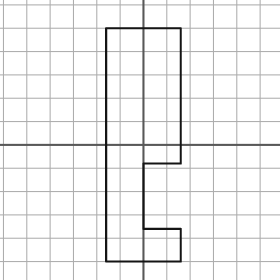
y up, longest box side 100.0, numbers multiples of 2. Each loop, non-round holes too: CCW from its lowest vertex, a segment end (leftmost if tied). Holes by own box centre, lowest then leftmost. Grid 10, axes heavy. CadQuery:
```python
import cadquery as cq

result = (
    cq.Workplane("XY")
    .moveTo(-16.0, -50.0)
    .lineTo(16.0, -50.0)
    .lineTo(16.0, -36.0)
    .lineTo(0.0, -36.0)
    .lineTo(0.0, -8.0)
    .lineTo(16.0, -8.0)
    .lineTo(16.0, 50.0)
    .lineTo(-16.0, 50.0)
    .close()
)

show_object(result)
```